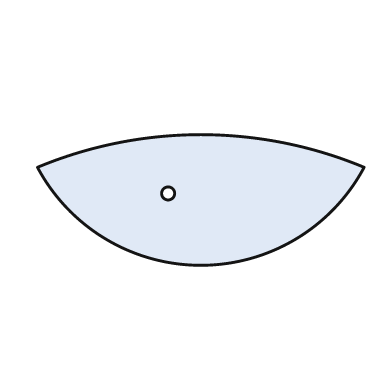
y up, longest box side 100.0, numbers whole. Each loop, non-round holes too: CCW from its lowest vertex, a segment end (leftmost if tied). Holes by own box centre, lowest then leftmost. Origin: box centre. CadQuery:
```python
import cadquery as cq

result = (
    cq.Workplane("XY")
    .moveTo(-50.0, 10.0)
    .threePointArc((0.0, -20.0), (50.0, 10.0))
    .threePointArc((0.0, 20.0), (-50.0, 10.0))
    .close()
    .moveTo(-10.0, 2.0)
    .circle(2.0)
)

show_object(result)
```